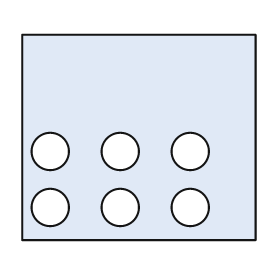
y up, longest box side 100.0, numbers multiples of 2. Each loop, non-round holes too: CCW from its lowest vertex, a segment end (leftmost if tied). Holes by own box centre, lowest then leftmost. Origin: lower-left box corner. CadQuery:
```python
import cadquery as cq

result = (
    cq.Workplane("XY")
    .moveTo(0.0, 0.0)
    .lineTo(100.0, 0.0)
    .lineTo(100.0, 88.0)
    .lineTo(0.0, 88.0)
    .close()
    .moveTo(12.0, 14.0)
    .circle(8.0)
    .moveTo(42.0, 14.0)
    .circle(8.0)
    .moveTo(72.0, 14.0)
    .circle(8.0)
    .moveTo(12.0, 38.0)
    .circle(8.0)
    .moveTo(42.0, 38.0)
    .circle(8.0)
    .moveTo(72.0, 38.0)
    .circle(8.0)
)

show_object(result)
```